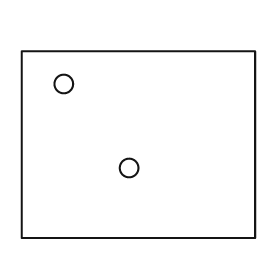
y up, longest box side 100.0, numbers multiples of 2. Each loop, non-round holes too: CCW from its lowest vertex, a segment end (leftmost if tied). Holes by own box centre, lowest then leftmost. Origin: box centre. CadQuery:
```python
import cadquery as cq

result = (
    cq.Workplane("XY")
    .moveTo(-50.0, -40.0)
    .lineTo(50.0, -40.0)
    .lineTo(50.0, 40.0)
    .lineTo(-50.0, 40.0)
    .close()
    .moveTo(-4.0, -10.0)
    .circle(4.0)
    .moveTo(-32.0, 26.0)
    .circle(4.0)
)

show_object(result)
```